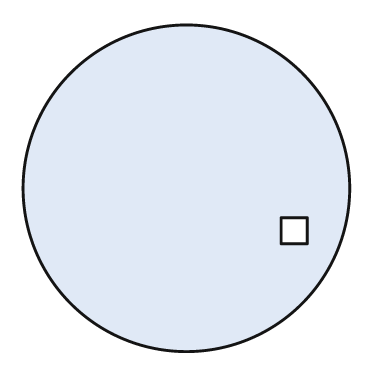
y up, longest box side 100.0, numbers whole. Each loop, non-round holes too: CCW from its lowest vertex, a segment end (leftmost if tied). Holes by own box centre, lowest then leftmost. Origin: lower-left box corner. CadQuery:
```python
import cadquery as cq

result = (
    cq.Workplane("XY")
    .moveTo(50.0, 50.0)
    .circle(50.0)
    .moveTo(79.0, 33.0)
    .lineTo(87.0, 33.0)
    .lineTo(87.0, 41.0)
    .lineTo(79.0, 41.0)
    .close()
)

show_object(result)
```